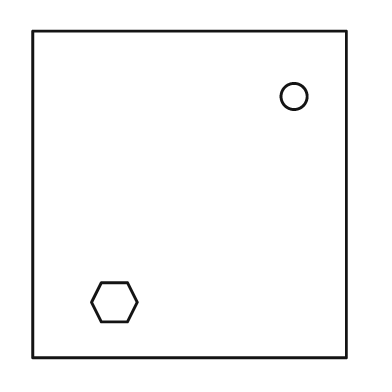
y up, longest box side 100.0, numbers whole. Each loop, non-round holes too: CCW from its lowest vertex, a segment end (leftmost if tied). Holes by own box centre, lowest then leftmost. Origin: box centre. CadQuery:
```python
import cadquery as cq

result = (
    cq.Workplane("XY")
    .moveTo(-48.0, -50.0)
    .lineTo(48.0, -50.0)
    .lineTo(48.0, 50.0)
    .lineTo(-48.0, 50.0)
    .close()
    .moveTo(-27.0, -39.0)
    .lineTo(-19.0, -39.0)
    .lineTo(-16.0, -33.0)
    .lineTo(-19.0, -27.0)
    .lineTo(-27.0, -27.0)
    .lineTo(-30.0, -33.0)
    .close()
    .moveTo(32.0, 30.0)
    .circle(4.0)
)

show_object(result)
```